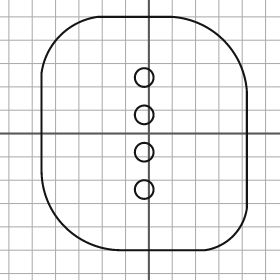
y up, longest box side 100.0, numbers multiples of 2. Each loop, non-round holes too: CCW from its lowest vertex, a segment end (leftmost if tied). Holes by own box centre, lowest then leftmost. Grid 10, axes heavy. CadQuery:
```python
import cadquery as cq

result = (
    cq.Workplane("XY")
    .moveTo(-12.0, -50.0)
    .lineTo(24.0, -50.0)
    .threePointArc((36.0, -44.0), (42.0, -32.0))
    .lineTo(42.0, 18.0)
    .threePointArc((32.0, 40.0), (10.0, 50.0))
    .lineTo(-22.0, 50.0)
    .threePointArc((-38.0, 42.0), (-46.0, 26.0))
    .lineTo(-46.0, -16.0)
    .threePointArc((-36.0, -40.0), (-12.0, -50.0))
    .close()
    .moveTo(-2.0, -24.0)
    .circle(4.0)
    .moveTo(-2.0, -8.0)
    .circle(4.0)
    .moveTo(-2.0, 8.0)
    .circle(4.0)
    .moveTo(-2.0, 24.0)
    .circle(4.0)
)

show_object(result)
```